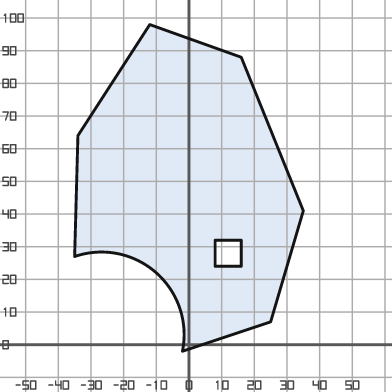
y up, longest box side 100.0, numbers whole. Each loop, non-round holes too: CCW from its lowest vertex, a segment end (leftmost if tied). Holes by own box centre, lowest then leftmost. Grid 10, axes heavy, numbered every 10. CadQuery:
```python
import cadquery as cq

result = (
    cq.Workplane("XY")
    .moveTo(-2.0, -2.0)
    .lineTo(25.0, 7.0)
    .lineTo(35.0, 41.0)
    .lineTo(16.0, 88.0)
    .lineTo(-12.0, 98.0)
    .lineTo(-34.0, 64.0)
    .lineTo(-35.0, 27.0)
    .threePointArc((-10.0, 22.0), (-2.0, -2.0))
    .close()
    .moveTo(8.0, 24.0)
    .lineTo(16.0, 24.0)
    .lineTo(16.0, 32.0)
    .lineTo(8.0, 32.0)
    .close()
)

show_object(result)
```